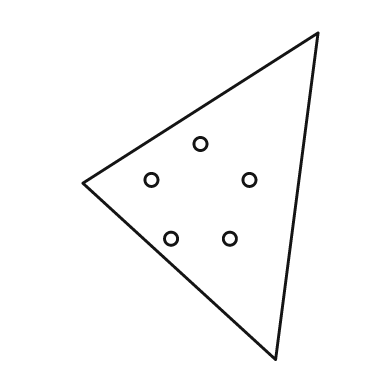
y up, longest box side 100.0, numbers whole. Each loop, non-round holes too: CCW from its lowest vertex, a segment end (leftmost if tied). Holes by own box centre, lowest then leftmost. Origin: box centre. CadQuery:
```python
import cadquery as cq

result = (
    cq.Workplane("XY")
    .moveTo(23.0, -50.0)
    .lineTo(36.0, 50.0)
    .lineTo(-36.0, 4.0)
    .close()
    .moveTo(-9.0, -13.0)
    .circle(2.0)
    .moveTo(9.0, -13.0)
    .circle(2.0)
    .moveTo(-15.0, 5.0)
    .circle(2.0)
    .moveTo(15.0, 5.0)
    .circle(2.0)
    .moveTo(0.0, 16.0)
    .circle(2.0)
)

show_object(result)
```